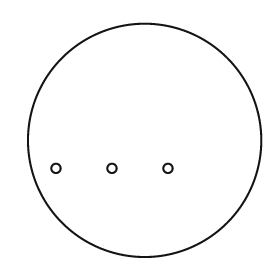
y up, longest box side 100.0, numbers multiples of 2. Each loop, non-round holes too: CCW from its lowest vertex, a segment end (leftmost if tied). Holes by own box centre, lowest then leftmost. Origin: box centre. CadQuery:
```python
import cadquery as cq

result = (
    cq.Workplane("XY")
    .moveTo(0.0, 0.0)
    .circle(50.0)
    .moveTo(-38.0, -12.0)
    .circle(2.0)
    .moveTo(-14.0, -12.0)
    .circle(2.0)
    .moveTo(10.0, -12.0)
    .circle(2.0)
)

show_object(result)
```